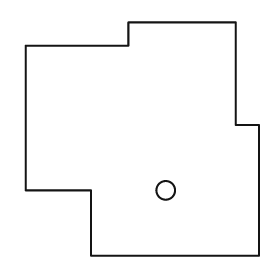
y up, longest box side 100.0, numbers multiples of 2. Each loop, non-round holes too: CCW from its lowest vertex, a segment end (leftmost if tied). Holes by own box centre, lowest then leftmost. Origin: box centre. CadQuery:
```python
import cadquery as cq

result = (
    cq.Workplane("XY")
    .moveTo(-22.0, -50.0)
    .lineTo(50.0, -50.0)
    .lineTo(50.0, 6.0)
    .lineTo(40.0, 6.0)
    .lineTo(40.0, 50.0)
    .lineTo(-6.0, 50.0)
    .lineTo(-6.0, 40.0)
    .lineTo(-50.0, 40.0)
    .lineTo(-50.0, -22.0)
    .lineTo(-22.0, -22.0)
    .close()
    .moveTo(10.0, -22.0)
    .circle(4.0)
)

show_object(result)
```